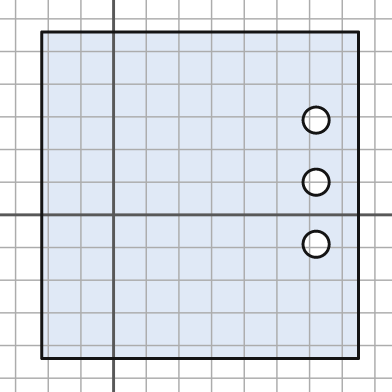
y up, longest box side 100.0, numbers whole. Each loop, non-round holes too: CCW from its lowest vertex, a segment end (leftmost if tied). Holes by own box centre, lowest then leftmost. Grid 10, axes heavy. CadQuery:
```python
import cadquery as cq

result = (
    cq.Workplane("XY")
    .moveTo(-22.0, -44.0)
    .lineTo(75.0, -44.0)
    .lineTo(75.0, 56.0)
    .lineTo(-22.0, 56.0)
    .close()
    .moveTo(62.0, -9.0)
    .circle(4.0)
    .moveTo(62.0, 10.0)
    .circle(4.0)
    .moveTo(62.0, 29.0)
    .circle(4.0)
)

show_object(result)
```